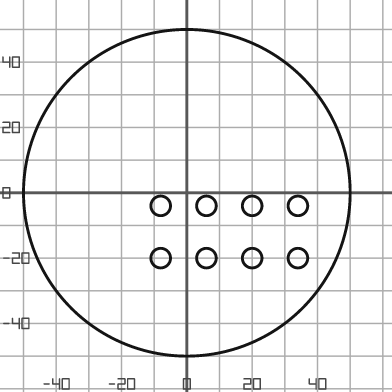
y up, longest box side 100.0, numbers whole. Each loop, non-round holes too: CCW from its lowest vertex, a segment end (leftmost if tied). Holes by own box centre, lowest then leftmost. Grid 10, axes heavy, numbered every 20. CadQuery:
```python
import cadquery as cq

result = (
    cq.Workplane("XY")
    .moveTo(0.0, 0.0)
    .circle(50.0)
    .moveTo(-8.0, -20.0)
    .circle(3.0)
    .moveTo(6.0, -20.0)
    .circle(3.0)
    .moveTo(20.0, -20.0)
    .circle(3.0)
    .moveTo(34.0, -20.0)
    .circle(3.0)
    .moveTo(-8.0, -4.0)
    .circle(3.0)
    .moveTo(6.0, -4.0)
    .circle(3.0)
    .moveTo(20.0, -4.0)
    .circle(3.0)
    .moveTo(34.0, -4.0)
    .circle(3.0)
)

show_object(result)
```